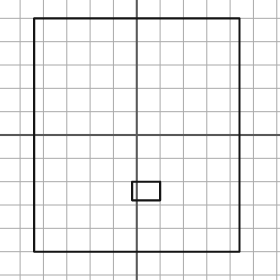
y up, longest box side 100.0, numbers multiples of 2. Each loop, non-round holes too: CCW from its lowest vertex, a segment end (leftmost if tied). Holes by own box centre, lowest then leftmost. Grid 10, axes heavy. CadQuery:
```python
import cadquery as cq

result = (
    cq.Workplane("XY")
    .moveTo(-44.0, -50.0)
    .lineTo(44.0, -50.0)
    .lineTo(44.0, 50.0)
    .lineTo(-44.0, 50.0)
    .close()
    .moveTo(-2.0, -28.0)
    .lineTo(10.0, -28.0)
    .lineTo(10.0, -20.0)
    .lineTo(-2.0, -20.0)
    .close()
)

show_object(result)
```